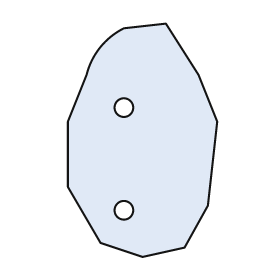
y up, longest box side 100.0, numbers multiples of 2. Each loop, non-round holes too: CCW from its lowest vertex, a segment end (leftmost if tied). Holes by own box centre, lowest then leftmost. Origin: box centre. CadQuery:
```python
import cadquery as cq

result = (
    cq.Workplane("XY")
    .moveTo(0.0, -50.0)
    .lineTo(18.0, -46.0)
    .lineTo(28.0, -28.0)
    .lineTo(32.0, 8.0)
    .lineTo(24.0, 28.0)
    .lineTo(10.0, 50.0)
    .lineTo(-8.0, 48.0)
    .threePointArc((-18.0, 40.0), (-24.0, 28.0))
    .lineTo(-32.0, 8.0)
    .lineTo(-32.0, -20.0)
    .lineTo(-18.0, -44.0)
    .close()
    .moveTo(-8.0, -30.0)
    .circle(4.0)
    .moveTo(-8.0, 14.0)
    .circle(4.0)
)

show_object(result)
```